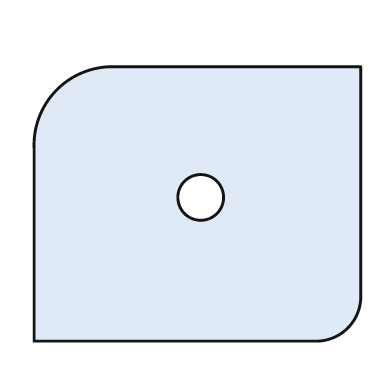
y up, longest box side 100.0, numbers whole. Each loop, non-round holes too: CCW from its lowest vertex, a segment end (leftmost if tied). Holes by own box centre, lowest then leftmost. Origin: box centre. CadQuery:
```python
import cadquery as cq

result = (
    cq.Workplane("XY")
    .moveTo(-50.0, -42.0)
    .lineTo(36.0, -42.0)
    .threePointArc((46.0, -38.0), (50.0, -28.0))
    .lineTo(50.0, 42.0)
    .lineTo(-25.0, 42.0)
    .threePointArc((-43.0, 35.0), (-50.0, 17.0))
    .close()
    .moveTo(1.0, 2.0)
    .circle(7.0)
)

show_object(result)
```